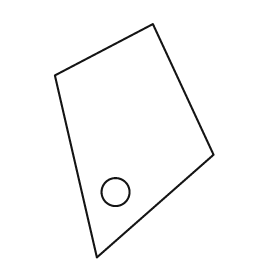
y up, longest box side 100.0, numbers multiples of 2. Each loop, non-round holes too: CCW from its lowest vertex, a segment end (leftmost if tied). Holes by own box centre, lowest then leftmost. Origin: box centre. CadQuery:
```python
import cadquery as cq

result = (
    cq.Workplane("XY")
    .moveTo(-16.0, -50.0)
    .lineTo(34.0, -6.0)
    .lineTo(8.0, 50.0)
    .lineTo(-34.0, 28.0)
    .close()
    .moveTo(-8.0, -22.0)
    .circle(6.0)
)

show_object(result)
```